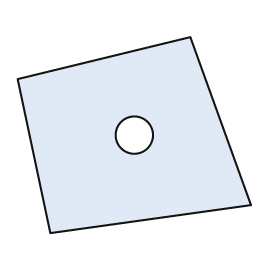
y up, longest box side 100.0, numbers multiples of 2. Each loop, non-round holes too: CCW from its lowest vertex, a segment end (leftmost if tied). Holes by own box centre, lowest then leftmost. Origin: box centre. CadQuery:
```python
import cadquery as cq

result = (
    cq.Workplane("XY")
    .moveTo(-36.0, -42.0)
    .lineTo(50.0, -30.0)
    .lineTo(24.0, 42.0)
    .lineTo(-50.0, 24.0)
    .close()
    .moveTo(0.0, 0.0)
    .circle(8.0)
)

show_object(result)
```